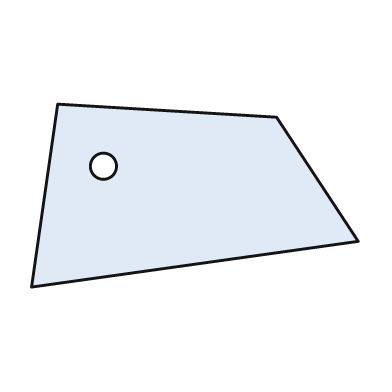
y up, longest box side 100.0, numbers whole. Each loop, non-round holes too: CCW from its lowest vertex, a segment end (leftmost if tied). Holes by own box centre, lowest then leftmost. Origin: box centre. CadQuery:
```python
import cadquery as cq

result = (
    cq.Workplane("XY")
    .moveTo(-50.0, -28.0)
    .lineTo(50.0, -14.0)
    .lineTo(25.0, 24.0)
    .lineTo(-42.0, 28.0)
    .close()
    .moveTo(-28.0, 9.0)
    .circle(4.0)
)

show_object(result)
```